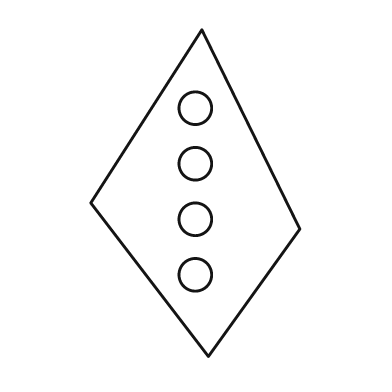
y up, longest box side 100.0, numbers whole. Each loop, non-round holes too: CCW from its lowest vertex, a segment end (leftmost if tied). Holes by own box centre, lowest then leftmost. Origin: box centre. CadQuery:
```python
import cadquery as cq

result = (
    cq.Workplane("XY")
    .moveTo(4.0, -50.0)
    .lineTo(32.0, -11.0)
    .lineTo(2.0, 50.0)
    .lineTo(-32.0, -3.0)
    .close()
    .moveTo(0.0, -25.0)
    .circle(5.0)
    .moveTo(0.0, -8.0)
    .circle(5.0)
    .moveTo(0.0, 9.0)
    .circle(5.0)
    .moveTo(0.0, 26.0)
    .circle(5.0)
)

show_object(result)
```